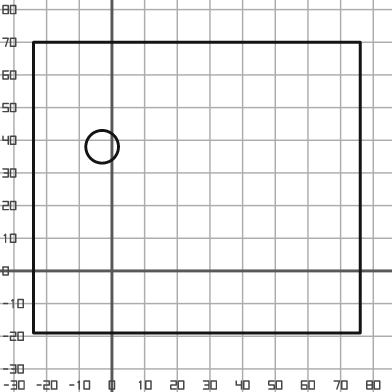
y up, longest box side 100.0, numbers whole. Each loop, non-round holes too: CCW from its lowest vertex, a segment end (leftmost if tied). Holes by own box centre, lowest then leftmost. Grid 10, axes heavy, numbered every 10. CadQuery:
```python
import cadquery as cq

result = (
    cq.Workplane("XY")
    .moveTo(-24.0, -19.0)
    .lineTo(76.0, -19.0)
    .lineTo(76.0, 70.0)
    .lineTo(-24.0, 70.0)
    .close()
    .moveTo(-3.0, 38.0)
    .circle(5.0)
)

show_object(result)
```